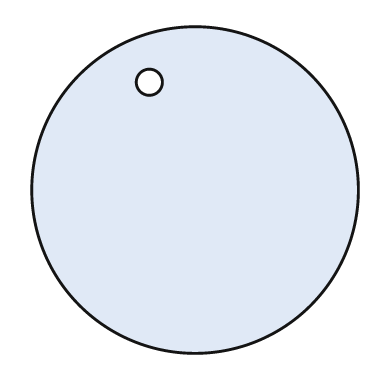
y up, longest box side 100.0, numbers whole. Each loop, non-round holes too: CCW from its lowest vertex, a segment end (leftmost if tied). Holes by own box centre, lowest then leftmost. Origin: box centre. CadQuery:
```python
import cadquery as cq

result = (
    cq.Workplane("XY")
    .moveTo(0.0, 0.0)
    .circle(50.0)
    .moveTo(-14.0, 33.0)
    .circle(4.0)
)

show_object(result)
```